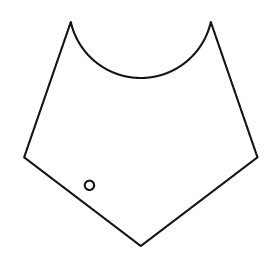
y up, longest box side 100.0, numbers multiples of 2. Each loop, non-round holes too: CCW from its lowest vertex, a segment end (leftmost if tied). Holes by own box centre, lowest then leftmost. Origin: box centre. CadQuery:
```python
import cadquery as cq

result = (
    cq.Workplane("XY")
    .moveTo(0.0, -48.0)
    .lineTo(50.0, -10.0)
    .lineTo(30.0, 48.0)
    .threePointArc((0.0, 24.0), (-30.0, 48.0))
    .lineTo(-50.0, -10.0)
    .close()
    .moveTo(-22.0, -22.0)
    .circle(2.0)
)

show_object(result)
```